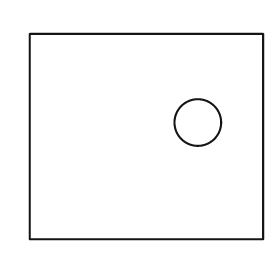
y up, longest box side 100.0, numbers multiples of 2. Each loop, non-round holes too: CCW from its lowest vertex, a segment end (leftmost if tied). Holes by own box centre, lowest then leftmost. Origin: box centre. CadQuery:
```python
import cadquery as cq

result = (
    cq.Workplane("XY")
    .moveTo(-50.0, -44.0)
    .lineTo(50.0, -44.0)
    .lineTo(50.0, 44.0)
    .lineTo(-50.0, 44.0)
    .close()
    .moveTo(22.0, 6.0)
    .circle(10.0)
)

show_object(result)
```